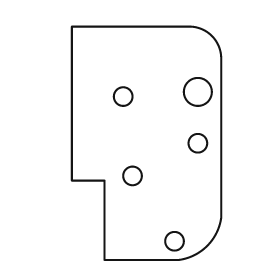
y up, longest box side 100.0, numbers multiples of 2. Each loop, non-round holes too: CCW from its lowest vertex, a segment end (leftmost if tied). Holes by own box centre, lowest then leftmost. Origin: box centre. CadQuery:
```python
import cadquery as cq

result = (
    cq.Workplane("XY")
    .moveTo(-18.0, -50.0)
    .lineTo(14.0, -50.0)
    .threePointArc((26.0, -44.0), (32.0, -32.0))
    .lineTo(32.0, 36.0)
    .threePointArc((28.0, 46.0), (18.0, 50.0))
    .lineTo(-32.0, 50.0)
    .lineTo(-32.0, -16.0)
    .lineTo(-18.0, -16.0)
    .close()
    .moveTo(12.0, -42.0)
    .circle(4.0)
    .moveTo(-6.0, -14.0)
    .circle(4.0)
    .moveTo(22.0, 0.0)
    .circle(4.0)
    .moveTo(-10.0, 20.0)
    .circle(4.0)
    .moveTo(22.0, 22.0)
    .circle(6.0)
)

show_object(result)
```